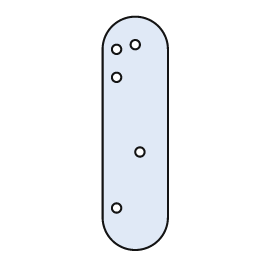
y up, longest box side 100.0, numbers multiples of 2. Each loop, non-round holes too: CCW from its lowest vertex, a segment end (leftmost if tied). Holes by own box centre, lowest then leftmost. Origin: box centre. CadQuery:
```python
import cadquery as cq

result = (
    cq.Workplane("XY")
    .moveTo(-14.0, -36.0)
    .threePointArc((0.0, -50.0), (14.0, -36.0))
    .lineTo(14.0, 36.0)
    .threePointArc((0.0, 50.0), (-14.0, 36.0))
    .close()
    .moveTo(-8.0, -32.0)
    .circle(2.0)
    .moveTo(2.0, -8.0)
    .circle(2.0)
    .moveTo(-8.0, 24.0)
    .circle(2.0)
    .moveTo(-8.0, 36.0)
    .circle(2.0)
    .moveTo(0.0, 38.0)
    .circle(2.0)
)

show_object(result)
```